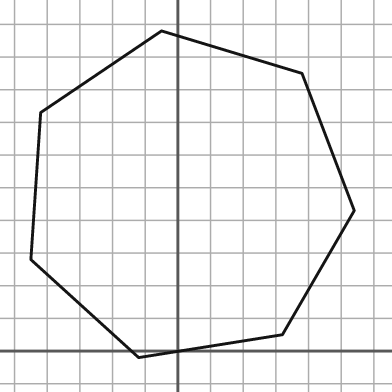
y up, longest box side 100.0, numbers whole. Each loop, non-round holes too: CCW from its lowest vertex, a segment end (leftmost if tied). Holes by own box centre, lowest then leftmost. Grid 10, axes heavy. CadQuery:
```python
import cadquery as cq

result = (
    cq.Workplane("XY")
    .moveTo(-12.0, -2.0)
    .lineTo(32.0, 5.0)
    .lineTo(54.0, 43.0)
    .lineTo(38.0, 85.0)
    .lineTo(-5.0, 98.0)
    .lineTo(-42.0, 73.0)
    .lineTo(-45.0, 28.0)
    .close()
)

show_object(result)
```